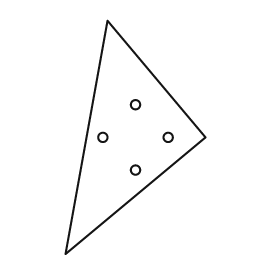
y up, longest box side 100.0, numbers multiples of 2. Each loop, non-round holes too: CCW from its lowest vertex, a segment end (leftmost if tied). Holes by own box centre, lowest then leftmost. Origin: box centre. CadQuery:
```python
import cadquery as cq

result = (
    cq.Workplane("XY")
    .moveTo(-30.0, -50.0)
    .lineTo(30.0, 0.0)
    .lineTo(-12.0, 50.0)
    .close()
    .moveTo(0.0, -14.0)
    .circle(2.0)
    .moveTo(-14.0, 0.0)
    .circle(2.0)
    .moveTo(14.0, 0.0)
    .circle(2.0)
    .moveTo(0.0, 14.0)
    .circle(2.0)
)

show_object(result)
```